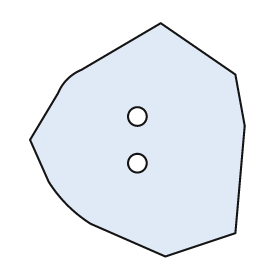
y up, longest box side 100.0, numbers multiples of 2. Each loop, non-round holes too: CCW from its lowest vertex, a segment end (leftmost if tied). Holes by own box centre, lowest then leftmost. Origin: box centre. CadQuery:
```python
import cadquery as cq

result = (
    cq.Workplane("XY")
    .moveTo(12.0, -50.0)
    .lineTo(42.0, -40.0)
    .lineTo(46.0, 6.0)
    .lineTo(42.0, 28.0)
    .lineTo(10.0, 50.0)
    .lineTo(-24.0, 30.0)
    .threePointArc((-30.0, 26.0), (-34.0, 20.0))
    .lineTo(-46.0, 0.0)
    .lineTo(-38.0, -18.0)
    .threePointArc((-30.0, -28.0), (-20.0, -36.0))
    .close()
    .moveTo(0.0, -10.0)
    .circle(4.0)
    .moveTo(0.0, 10.0)
    .circle(4.0)
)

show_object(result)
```